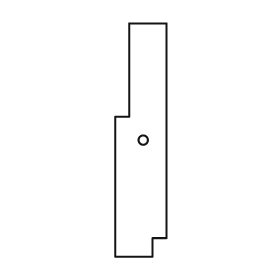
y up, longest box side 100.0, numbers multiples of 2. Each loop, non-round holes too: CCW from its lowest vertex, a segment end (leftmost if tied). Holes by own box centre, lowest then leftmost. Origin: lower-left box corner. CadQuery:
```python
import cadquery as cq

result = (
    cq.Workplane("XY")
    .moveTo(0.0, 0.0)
    .lineTo(16.0, 0.0)
    .lineTo(16.0, 8.0)
    .lineTo(22.0, 8.0)
    .lineTo(22.0, 100.0)
    .lineTo(6.0, 100.0)
    .lineTo(6.0, 60.0)
    .lineTo(0.0, 60.0)
    .close()
    .moveTo(12.0, 50.0)
    .circle(2.0)
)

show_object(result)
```